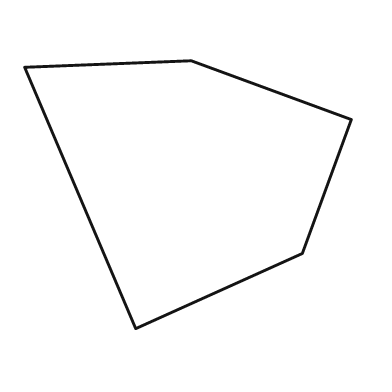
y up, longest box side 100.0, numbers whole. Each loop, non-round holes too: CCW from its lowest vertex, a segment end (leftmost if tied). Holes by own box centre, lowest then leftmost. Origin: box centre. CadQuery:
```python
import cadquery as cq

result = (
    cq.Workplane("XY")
    .moveTo(-16.0, -41.0)
    .lineTo(35.0, -18.0)
    .lineTo(50.0, 23.0)
    .lineTo(1.0, 41.0)
    .lineTo(-50.0, 39.0)
    .close()
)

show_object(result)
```